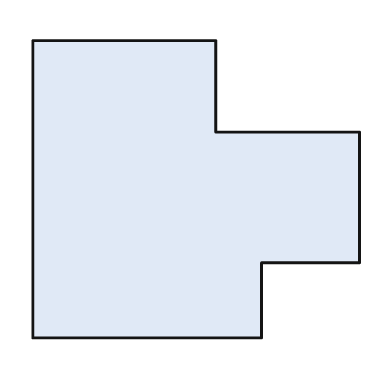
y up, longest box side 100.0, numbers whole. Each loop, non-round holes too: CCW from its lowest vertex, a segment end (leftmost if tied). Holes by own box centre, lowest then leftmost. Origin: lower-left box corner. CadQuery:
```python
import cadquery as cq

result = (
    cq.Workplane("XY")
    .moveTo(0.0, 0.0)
    .lineTo(70.0, 0.0)
    .lineTo(70.0, 23.0)
    .lineTo(100.0, 23.0)
    .lineTo(100.0, 63.0)
    .lineTo(56.0, 63.0)
    .lineTo(56.0, 91.0)
    .lineTo(0.0, 91.0)
    .close()
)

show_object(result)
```